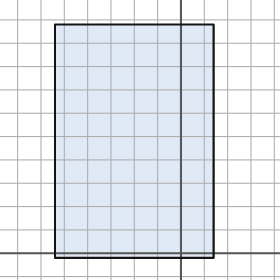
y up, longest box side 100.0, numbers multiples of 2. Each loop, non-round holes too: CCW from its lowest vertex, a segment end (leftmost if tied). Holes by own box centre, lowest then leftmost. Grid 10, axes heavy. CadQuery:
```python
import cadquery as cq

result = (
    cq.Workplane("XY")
    .moveTo(-54.0, -2.0)
    .lineTo(14.0, -2.0)
    .lineTo(14.0, 98.0)
    .lineTo(-54.0, 98.0)
    .close()
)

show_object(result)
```